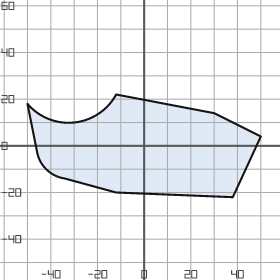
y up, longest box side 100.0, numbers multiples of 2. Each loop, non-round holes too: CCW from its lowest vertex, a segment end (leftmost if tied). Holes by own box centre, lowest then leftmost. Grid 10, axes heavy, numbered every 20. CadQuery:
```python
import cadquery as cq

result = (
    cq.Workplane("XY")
    .moveTo(38.0, -22.0)
    .lineTo(50.0, 4.0)
    .lineTo(30.0, 14.0)
    .lineTo(-12.0, 22.0)
    .threePointArc((-30.0, 10.0), (-50.0, 18.0))
    .lineTo(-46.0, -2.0)
    .threePointArc((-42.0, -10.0), (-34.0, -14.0))
    .lineTo(-12.0, -20.0)
    .close()
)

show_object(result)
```